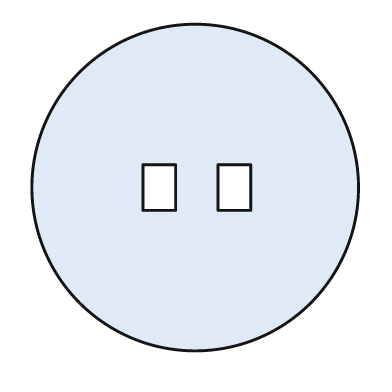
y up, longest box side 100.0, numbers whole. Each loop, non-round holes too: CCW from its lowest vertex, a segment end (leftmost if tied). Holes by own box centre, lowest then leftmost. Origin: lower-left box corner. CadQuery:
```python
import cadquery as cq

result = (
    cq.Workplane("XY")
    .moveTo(50.0, 50.0)
    .circle(50.0)
    .moveTo(34.0, 43.0)
    .lineTo(44.0, 43.0)
    .lineTo(44.0, 57.0)
    .lineTo(34.0, 57.0)
    .close()
    .moveTo(57.0, 43.0)
    .lineTo(67.0, 43.0)
    .lineTo(67.0, 57.0)
    .lineTo(57.0, 57.0)
    .close()
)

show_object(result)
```